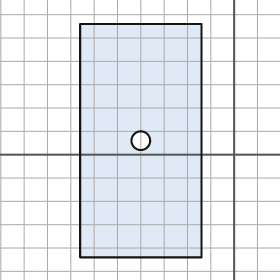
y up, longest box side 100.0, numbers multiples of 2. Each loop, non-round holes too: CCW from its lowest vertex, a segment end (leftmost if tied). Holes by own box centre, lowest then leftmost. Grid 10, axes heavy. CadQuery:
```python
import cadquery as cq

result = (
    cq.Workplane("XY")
    .moveTo(-66.0, -44.0)
    .lineTo(-14.0, -44.0)
    .lineTo(-14.0, 56.0)
    .lineTo(-66.0, 56.0)
    .close()
    .moveTo(-40.0, 6.0)
    .circle(4.0)
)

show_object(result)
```